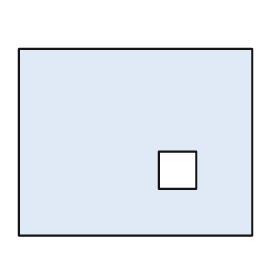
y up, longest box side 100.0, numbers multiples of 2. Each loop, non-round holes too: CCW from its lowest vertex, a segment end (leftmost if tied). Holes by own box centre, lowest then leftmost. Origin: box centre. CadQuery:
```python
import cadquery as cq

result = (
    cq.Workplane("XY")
    .moveTo(-50.0, -40.0)
    .lineTo(50.0, -40.0)
    .lineTo(50.0, 40.0)
    .lineTo(-50.0, 40.0)
    .close()
    .moveTo(10.0, -20.0)
    .lineTo(26.0, -20.0)
    .lineTo(26.0, -4.0)
    .lineTo(10.0, -4.0)
    .close()
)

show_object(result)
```